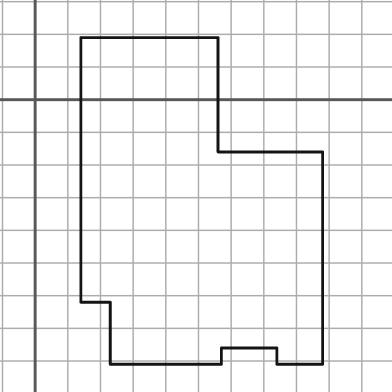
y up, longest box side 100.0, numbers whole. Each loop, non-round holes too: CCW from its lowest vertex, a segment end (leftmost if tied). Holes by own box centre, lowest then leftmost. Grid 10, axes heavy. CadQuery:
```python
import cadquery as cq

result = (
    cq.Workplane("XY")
    .moveTo(23.0, -81.0)
    .lineTo(57.0, -81.0)
    .lineTo(57.0, -76.0)
    .lineTo(74.0, -76.0)
    .lineTo(74.0, -81.0)
    .lineTo(88.0, -81.0)
    .lineTo(88.0, -16.0)
    .lineTo(56.0, -16.0)
    .lineTo(56.0, 19.0)
    .lineTo(14.0, 19.0)
    .lineTo(14.0, -62.0)
    .lineTo(23.0, -62.0)
    .close()
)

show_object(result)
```